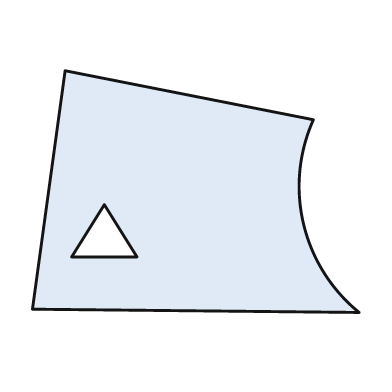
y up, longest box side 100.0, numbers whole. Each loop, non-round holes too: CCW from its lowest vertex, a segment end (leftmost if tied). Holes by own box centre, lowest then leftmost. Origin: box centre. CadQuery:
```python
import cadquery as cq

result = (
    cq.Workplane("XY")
    .moveTo(50.0, -37.0)
    .threePointArc((33.0, -10.0), (36.0, 22.0))
    .lineTo(-40.0, 37.0)
    .lineTo(-50.0, -36.0)
    .close()
    .moveTo(-38.0, -20.0)
    .lineTo(-18.0, -20.0)
    .lineTo(-28.0, -4.0)
    .close()
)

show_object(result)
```